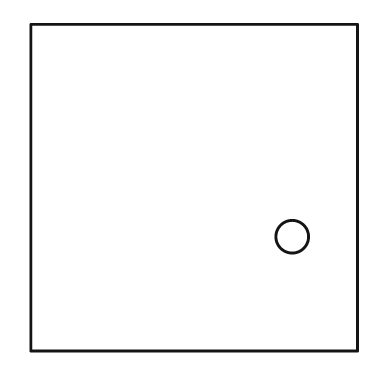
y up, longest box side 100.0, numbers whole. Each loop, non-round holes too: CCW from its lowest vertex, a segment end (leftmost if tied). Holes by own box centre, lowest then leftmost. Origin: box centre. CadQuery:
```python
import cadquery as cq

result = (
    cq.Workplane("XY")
    .moveTo(-50.0, -50.0)
    .lineTo(50.0, -50.0)
    .lineTo(50.0, 50.0)
    .lineTo(-50.0, 50.0)
    .close()
    .moveTo(30.0, -15.0)
    .circle(5.0)
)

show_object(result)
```